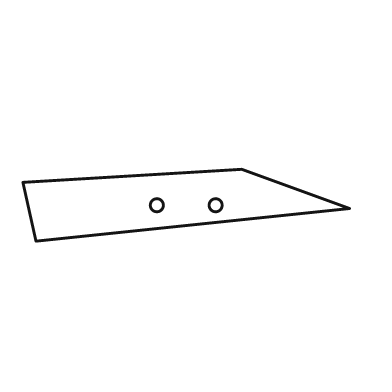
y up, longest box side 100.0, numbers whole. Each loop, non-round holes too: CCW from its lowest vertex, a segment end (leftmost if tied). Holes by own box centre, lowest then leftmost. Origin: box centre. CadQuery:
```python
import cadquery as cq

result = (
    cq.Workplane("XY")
    .moveTo(-46.0, -11.0)
    .lineTo(50.0, -1.0)
    .lineTo(17.0, 11.0)
    .lineTo(-50.0, 7.0)
    .close()
    .moveTo(-9.0, 0.0)
    .circle(2.0)
    .moveTo(9.0, 0.0)
    .circle(2.0)
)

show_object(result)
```